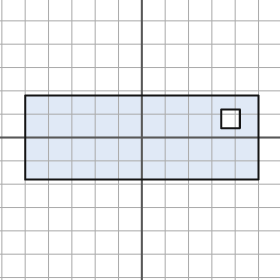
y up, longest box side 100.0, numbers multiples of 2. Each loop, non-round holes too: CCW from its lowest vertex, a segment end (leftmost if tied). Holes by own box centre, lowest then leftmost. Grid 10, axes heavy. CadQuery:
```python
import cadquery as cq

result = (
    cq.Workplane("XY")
    .moveTo(-50.0, -18.0)
    .lineTo(50.0, -18.0)
    .lineTo(50.0, 18.0)
    .lineTo(-50.0, 18.0)
    .close()
    .moveTo(34.0, 4.0)
    .lineTo(42.0, 4.0)
    .lineTo(42.0, 12.0)
    .lineTo(34.0, 12.0)
    .close()
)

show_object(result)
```